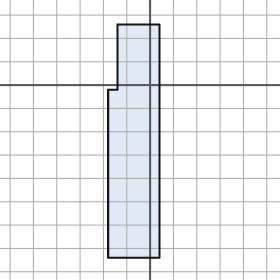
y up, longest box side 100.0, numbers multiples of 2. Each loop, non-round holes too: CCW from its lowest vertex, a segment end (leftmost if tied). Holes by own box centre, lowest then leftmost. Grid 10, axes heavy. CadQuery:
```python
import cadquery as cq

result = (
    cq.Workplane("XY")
    .moveTo(-18.0, -74.0)
    .lineTo(4.0, -74.0)
    .lineTo(4.0, 26.0)
    .lineTo(-14.0, 26.0)
    .lineTo(-14.0, -2.0)
    .lineTo(-18.0, -2.0)
    .close()
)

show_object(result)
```